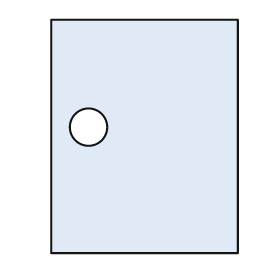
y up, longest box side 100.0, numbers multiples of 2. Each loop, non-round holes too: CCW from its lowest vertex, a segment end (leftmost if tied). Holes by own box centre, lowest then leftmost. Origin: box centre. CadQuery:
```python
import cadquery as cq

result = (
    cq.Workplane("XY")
    .moveTo(-40.0, -50.0)
    .lineTo(40.0, -50.0)
    .lineTo(40.0, 50.0)
    .lineTo(-40.0, 50.0)
    .close()
    .moveTo(-24.0, 4.0)
    .circle(8.0)
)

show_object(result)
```